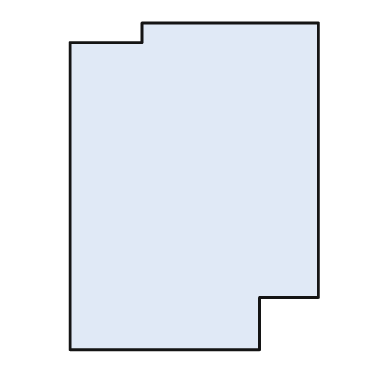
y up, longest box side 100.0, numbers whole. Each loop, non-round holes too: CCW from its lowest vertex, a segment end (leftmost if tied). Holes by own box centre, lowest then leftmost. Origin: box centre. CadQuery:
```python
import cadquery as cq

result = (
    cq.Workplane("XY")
    .moveTo(-38.0, -50.0)
    .lineTo(20.0, -50.0)
    .lineTo(20.0, -34.0)
    .lineTo(38.0, -34.0)
    .lineTo(38.0, 50.0)
    .lineTo(-16.0, 50.0)
    .lineTo(-16.0, 44.0)
    .lineTo(-38.0, 44.0)
    .close()
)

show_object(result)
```